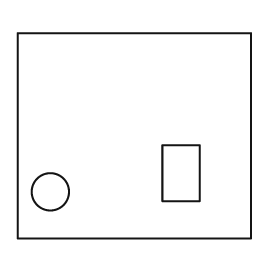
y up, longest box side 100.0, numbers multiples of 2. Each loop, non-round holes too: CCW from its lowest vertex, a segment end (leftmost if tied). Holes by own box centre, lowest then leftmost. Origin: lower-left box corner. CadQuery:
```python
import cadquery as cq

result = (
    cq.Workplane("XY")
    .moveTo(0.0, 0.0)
    .lineTo(100.0, 0.0)
    .lineTo(100.0, 88.0)
    .lineTo(0.0, 88.0)
    .close()
    .moveTo(14.0, 20.0)
    .circle(8.0)
    .moveTo(62.0, 16.0)
    .lineTo(78.0, 16.0)
    .lineTo(78.0, 40.0)
    .lineTo(62.0, 40.0)
    .close()
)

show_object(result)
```